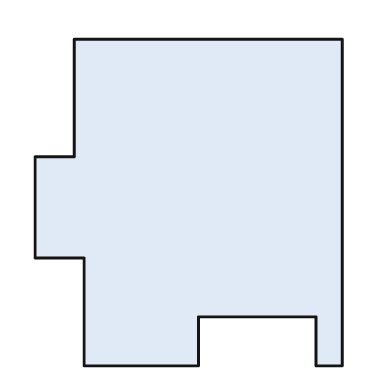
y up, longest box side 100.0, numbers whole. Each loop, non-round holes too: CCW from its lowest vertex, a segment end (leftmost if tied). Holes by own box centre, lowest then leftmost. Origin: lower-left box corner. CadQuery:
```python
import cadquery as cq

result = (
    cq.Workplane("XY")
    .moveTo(15.0, 0.0)
    .lineTo(50.0, 0.0)
    .lineTo(50.0, 15.0)
    .lineTo(86.0, 15.0)
    .lineTo(86.0, 0.0)
    .lineTo(94.0, 0.0)
    .lineTo(94.0, 100.0)
    .lineTo(12.0, 100.0)
    .lineTo(12.0, 64.0)
    .lineTo(0.0, 64.0)
    .lineTo(0.0, 33.0)
    .lineTo(15.0, 33.0)
    .close()
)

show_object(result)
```